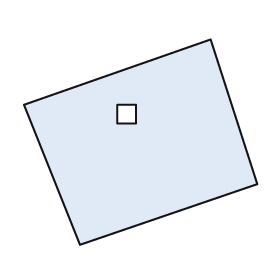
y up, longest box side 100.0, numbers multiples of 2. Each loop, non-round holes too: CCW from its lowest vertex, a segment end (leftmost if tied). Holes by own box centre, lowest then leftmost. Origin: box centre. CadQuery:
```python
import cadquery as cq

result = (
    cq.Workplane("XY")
    .moveTo(-26.0, -44.0)
    .lineTo(50.0, -18.0)
    .lineTo(30.0, 44.0)
    .lineTo(-50.0, 16.0)
    .close()
    .moveTo(-10.0, 8.0)
    .lineTo(-2.0, 8.0)
    .lineTo(-2.0, 16.0)
    .lineTo(-10.0, 16.0)
    .close()
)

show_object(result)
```